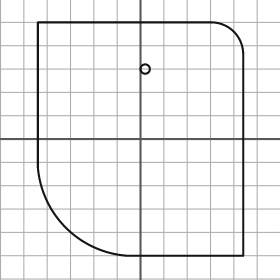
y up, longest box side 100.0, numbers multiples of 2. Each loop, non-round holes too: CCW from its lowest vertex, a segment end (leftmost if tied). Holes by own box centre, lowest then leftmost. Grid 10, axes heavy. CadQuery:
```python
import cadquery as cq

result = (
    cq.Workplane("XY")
    .moveTo(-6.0, -50.0)
    .lineTo(44.0, -50.0)
    .lineTo(44.0, 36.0)
    .threePointArc((40.0, 46.0), (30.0, 50.0))
    .lineTo(-44.0, 50.0)
    .lineTo(-44.0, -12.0)
    .threePointArc((-32.0, -38.0), (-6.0, -50.0))
    .close()
    .moveTo(2.0, 30.0)
    .circle(2.0)
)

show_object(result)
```